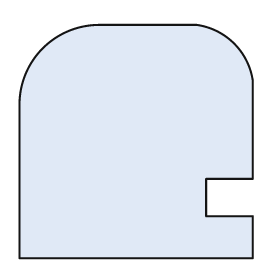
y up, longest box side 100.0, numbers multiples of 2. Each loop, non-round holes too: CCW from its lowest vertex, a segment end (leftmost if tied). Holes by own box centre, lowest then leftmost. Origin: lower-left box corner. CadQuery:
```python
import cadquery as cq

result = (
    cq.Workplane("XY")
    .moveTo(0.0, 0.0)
    .lineTo(100.0, 0.0)
    .lineTo(100.0, 18.0)
    .lineTo(80.0, 18.0)
    .lineTo(80.0, 34.0)
    .lineTo(100.0, 34.0)
    .lineTo(100.0, 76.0)
    .threePointArc((92.0, 92.0), (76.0, 100.0))
    .lineTo(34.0, 100.0)
    .threePointArc((10.0, 90.0), (0.0, 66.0))
    .close()
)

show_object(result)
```